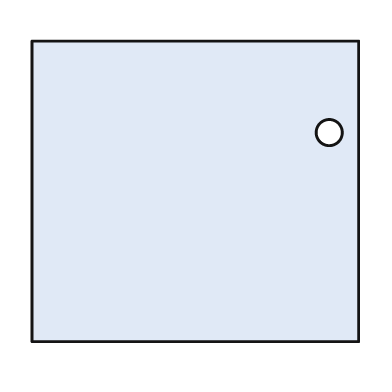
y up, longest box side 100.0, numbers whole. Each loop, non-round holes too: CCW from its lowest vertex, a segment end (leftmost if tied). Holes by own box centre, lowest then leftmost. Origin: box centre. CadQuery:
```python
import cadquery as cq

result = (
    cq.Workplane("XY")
    .moveTo(-50.0, -46.0)
    .lineTo(50.0, -46.0)
    .lineTo(50.0, 46.0)
    .lineTo(-50.0, 46.0)
    .close()
    .moveTo(41.0, 18.0)
    .circle(4.0)
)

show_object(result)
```